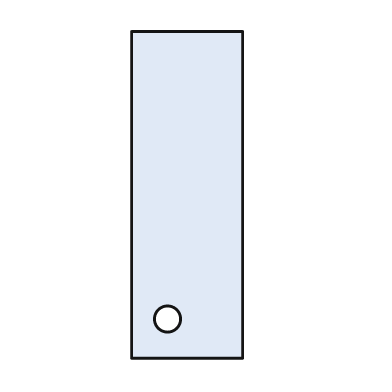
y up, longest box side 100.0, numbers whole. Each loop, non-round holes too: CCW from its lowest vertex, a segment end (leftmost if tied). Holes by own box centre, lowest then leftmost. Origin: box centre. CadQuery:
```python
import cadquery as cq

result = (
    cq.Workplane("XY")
    .moveTo(-17.0, -50.0)
    .lineTo(17.0, -50.0)
    .lineTo(17.0, 50.0)
    .lineTo(-17.0, 50.0)
    .close()
    .moveTo(-6.0, -38.0)
    .circle(4.0)
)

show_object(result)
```